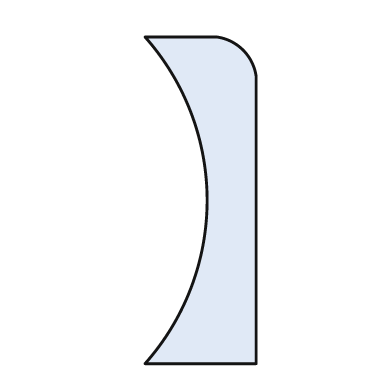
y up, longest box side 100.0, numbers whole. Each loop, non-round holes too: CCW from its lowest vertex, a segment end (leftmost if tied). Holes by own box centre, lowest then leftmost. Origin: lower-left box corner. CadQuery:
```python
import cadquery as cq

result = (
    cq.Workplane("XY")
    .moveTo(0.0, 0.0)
    .lineTo(34.0, 0.0)
    .lineTo(34.0, 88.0)
    .threePointArc((30.0, 96.0), (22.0, 100.0))
    .lineTo(0.0, 100.0)
    .threePointArc((19.0, 50.0), (0.0, 0.0))
    .close()
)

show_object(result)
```